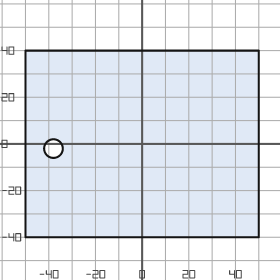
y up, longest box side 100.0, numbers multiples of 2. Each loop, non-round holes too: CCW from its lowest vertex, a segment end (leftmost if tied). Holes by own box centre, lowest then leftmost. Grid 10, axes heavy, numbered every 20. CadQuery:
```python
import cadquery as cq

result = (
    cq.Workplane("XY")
    .moveTo(-50.0, -40.0)
    .lineTo(50.0, -40.0)
    .lineTo(50.0, 40.0)
    .lineTo(-50.0, 40.0)
    .close()
    .moveTo(-38.0, -2.0)
    .circle(4.0)
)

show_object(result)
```